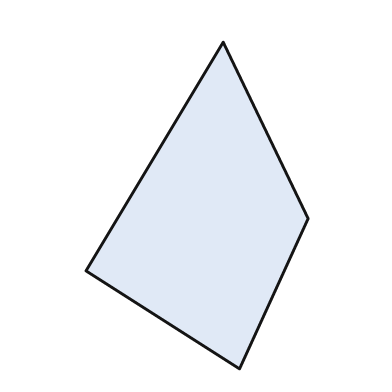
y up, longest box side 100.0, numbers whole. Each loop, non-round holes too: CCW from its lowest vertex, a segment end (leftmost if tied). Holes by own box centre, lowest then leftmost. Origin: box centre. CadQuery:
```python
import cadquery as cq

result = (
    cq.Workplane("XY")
    .moveTo(13.0, -50.0)
    .lineTo(34.0, -4.0)
    .lineTo(8.0, 50.0)
    .lineTo(-34.0, -20.0)
    .close()
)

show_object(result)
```